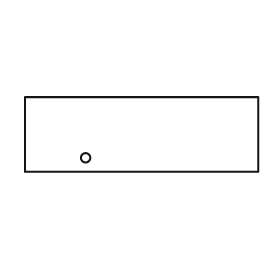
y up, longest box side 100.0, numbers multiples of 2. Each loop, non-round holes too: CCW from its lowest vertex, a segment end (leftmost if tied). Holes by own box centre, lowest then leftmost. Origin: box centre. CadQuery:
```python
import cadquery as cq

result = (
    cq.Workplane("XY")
    .moveTo(-50.0, -16.0)
    .lineTo(50.0, -16.0)
    .lineTo(50.0, 16.0)
    .lineTo(-50.0, 16.0)
    .close()
    .moveTo(-24.0, -10.0)
    .circle(2.0)
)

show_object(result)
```